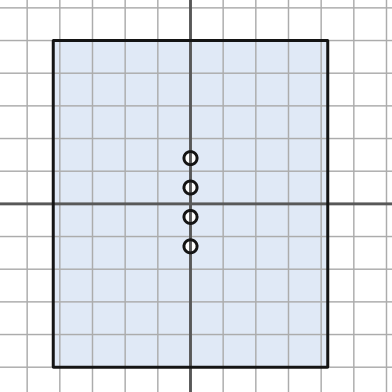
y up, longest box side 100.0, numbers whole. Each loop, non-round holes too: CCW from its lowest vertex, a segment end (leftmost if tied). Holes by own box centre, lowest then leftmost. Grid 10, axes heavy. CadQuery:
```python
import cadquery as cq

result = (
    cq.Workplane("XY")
    .moveTo(-42.0, -50.0)
    .lineTo(42.0, -50.0)
    .lineTo(42.0, 50.0)
    .lineTo(-42.0, 50.0)
    .close()
    .moveTo(0.0, -13.0)
    .circle(2.0)
    .moveTo(0.0, -4.0)
    .circle(2.0)
    .moveTo(0.0, 5.0)
    .circle(2.0)
    .moveTo(0.0, 14.0)
    .circle(2.0)
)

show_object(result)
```